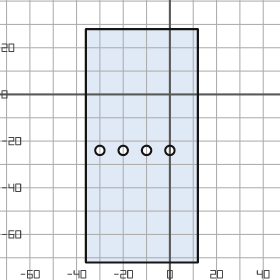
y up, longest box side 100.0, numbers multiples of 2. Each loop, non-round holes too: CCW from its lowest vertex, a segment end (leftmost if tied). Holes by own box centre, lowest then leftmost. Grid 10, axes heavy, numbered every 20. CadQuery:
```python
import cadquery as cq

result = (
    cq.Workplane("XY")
    .moveTo(-36.0, -72.0)
    .lineTo(12.0, -72.0)
    .lineTo(12.0, 28.0)
    .lineTo(-36.0, 28.0)
    .close()
    .moveTo(-30.0, -24.0)
    .circle(2.0)
    .moveTo(-20.0, -24.0)
    .circle(2.0)
    .moveTo(-10.0, -24.0)
    .circle(2.0)
    .moveTo(0.0, -24.0)
    .circle(2.0)
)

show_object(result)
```